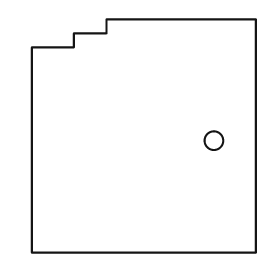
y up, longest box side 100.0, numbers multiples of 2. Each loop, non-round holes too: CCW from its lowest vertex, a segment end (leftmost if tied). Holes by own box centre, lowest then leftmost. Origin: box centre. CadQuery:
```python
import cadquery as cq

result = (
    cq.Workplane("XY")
    .moveTo(-48.0, -50.0)
    .lineTo(48.0, -50.0)
    .lineTo(48.0, 50.0)
    .lineTo(-16.0, 50.0)
    .lineTo(-16.0, 44.0)
    .lineTo(-30.0, 44.0)
    .lineTo(-30.0, 38.0)
    .lineTo(-48.0, 38.0)
    .close()
    .moveTo(30.0, -2.0)
    .circle(4.0)
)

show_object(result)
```